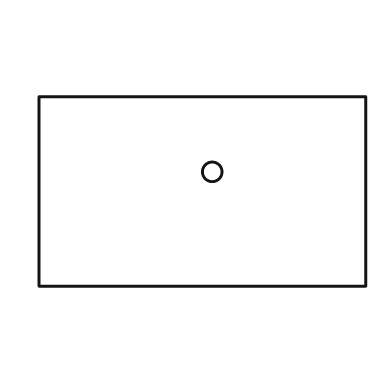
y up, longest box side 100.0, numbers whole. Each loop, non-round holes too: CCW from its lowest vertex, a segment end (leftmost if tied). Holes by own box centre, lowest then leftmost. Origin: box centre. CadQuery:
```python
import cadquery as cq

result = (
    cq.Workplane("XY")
    .moveTo(-50.0, -29.0)
    .lineTo(50.0, -29.0)
    .lineTo(50.0, 29.0)
    .lineTo(-50.0, 29.0)
    .close()
    .moveTo(3.0, 6.0)
    .circle(3.0)
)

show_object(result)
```